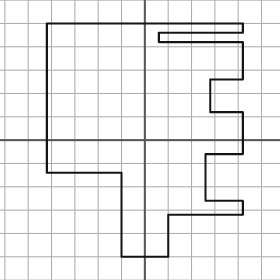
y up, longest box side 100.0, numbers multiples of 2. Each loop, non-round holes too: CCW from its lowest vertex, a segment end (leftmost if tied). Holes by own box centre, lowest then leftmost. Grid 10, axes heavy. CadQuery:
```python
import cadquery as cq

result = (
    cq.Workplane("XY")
    .moveTo(-10.0, -50.0)
    .lineTo(10.0, -50.0)
    .lineTo(10.0, -32.0)
    .lineTo(42.0, -32.0)
    .lineTo(42.0, -26.0)
    .lineTo(26.0, -26.0)
    .lineTo(26.0, -6.0)
    .lineTo(42.0, -6.0)
    .lineTo(42.0, 12.0)
    .lineTo(28.0, 12.0)
    .lineTo(28.0, 26.0)
    .lineTo(42.0, 26.0)
    .lineTo(42.0, 42.0)
    .lineTo(6.0, 42.0)
    .lineTo(6.0, 46.0)
    .lineTo(42.0, 46.0)
    .lineTo(42.0, 50.0)
    .lineTo(-42.0, 50.0)
    .lineTo(-42.0, -14.0)
    .lineTo(-10.0, -14.0)
    .close()
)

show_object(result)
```